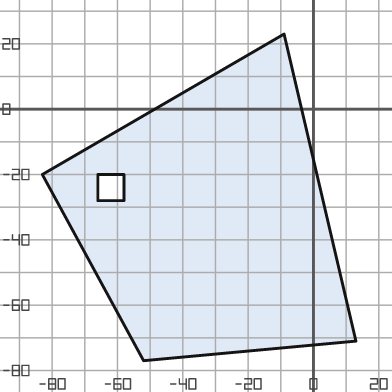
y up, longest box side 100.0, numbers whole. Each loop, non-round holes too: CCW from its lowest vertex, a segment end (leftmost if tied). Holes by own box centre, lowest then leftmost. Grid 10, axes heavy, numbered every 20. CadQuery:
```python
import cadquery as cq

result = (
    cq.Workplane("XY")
    .moveTo(-52.0, -77.0)
    .lineTo(13.0, -71.0)
    .lineTo(-9.0, 23.0)
    .lineTo(-83.0, -20.0)
    .close()
    .moveTo(-66.0, -28.0)
    .lineTo(-58.0, -28.0)
    .lineTo(-58.0, -20.0)
    .lineTo(-66.0, -20.0)
    .close()
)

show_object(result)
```